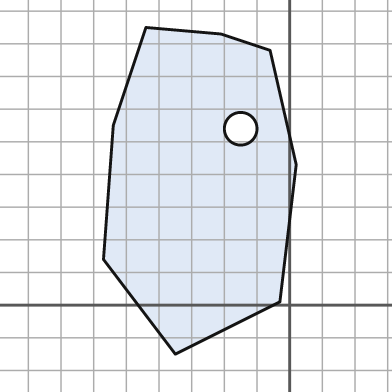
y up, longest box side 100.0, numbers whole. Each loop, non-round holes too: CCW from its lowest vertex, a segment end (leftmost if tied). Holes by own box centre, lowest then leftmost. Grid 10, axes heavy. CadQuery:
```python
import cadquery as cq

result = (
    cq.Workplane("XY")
    .moveTo(-35.0, -15.0)
    .lineTo(-3.0, 1.0)
    .lineTo(2.0, 43.0)
    .lineTo(-6.0, 78.0)
    .lineTo(-21.0, 83.0)
    .lineTo(-44.0, 85.0)
    .lineTo(-54.0, 55.0)
    .lineTo(-57.0, 14.0)
    .close()
    .moveTo(-15.0, 54.0)
    .circle(5.0)
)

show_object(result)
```